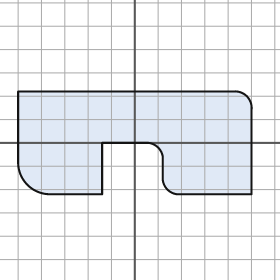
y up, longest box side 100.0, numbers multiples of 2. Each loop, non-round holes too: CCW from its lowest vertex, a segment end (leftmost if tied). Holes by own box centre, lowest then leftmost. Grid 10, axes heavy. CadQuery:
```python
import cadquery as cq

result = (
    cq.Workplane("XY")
    .moveTo(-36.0, -22.0)
    .lineTo(-14.0, -22.0)
    .lineTo(-14.0, 0.0)
    .lineTo(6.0, 0.0)
    .threePointArc((10.0, -2.0), (12.0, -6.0))
    .lineTo(12.0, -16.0)
    .threePointArc((14.0, -20.0), (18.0, -22.0))
    .lineTo(50.0, -22.0)
    .lineTo(50.0, 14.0)
    .threePointArc((48.0, 20.0), (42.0, 22.0))
    .lineTo(-50.0, 22.0)
    .lineTo(-50.0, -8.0)
    .threePointArc((-46.0, -18.0), (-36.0, -22.0))
    .close()
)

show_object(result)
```